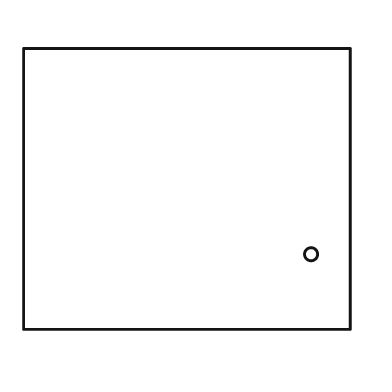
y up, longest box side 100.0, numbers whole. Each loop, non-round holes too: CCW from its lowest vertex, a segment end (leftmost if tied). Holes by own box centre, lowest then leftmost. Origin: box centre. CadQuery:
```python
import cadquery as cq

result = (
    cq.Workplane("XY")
    .moveTo(-50.0, -43.0)
    .lineTo(50.0, -43.0)
    .lineTo(50.0, 43.0)
    .lineTo(-50.0, 43.0)
    .close()
    .moveTo(38.0, -20.0)
    .circle(2.0)
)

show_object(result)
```